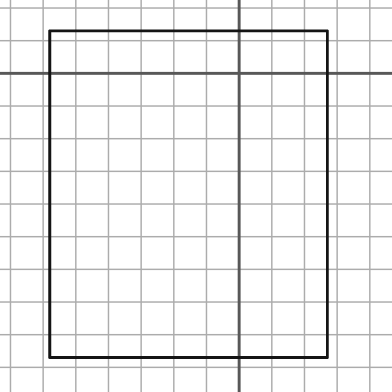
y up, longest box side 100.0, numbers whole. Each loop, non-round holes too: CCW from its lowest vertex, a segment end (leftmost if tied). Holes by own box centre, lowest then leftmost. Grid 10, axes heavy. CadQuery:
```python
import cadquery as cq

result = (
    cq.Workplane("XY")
    .moveTo(-58.0, -87.0)
    .lineTo(27.0, -87.0)
    .lineTo(27.0, 13.0)
    .lineTo(-58.0, 13.0)
    .close()
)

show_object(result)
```